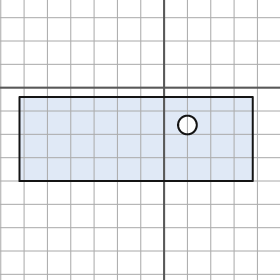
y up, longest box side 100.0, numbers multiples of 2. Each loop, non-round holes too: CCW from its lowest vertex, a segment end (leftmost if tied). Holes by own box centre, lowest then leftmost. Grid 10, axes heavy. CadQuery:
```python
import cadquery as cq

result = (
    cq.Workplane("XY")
    .moveTo(-62.0, -40.0)
    .lineTo(38.0, -40.0)
    .lineTo(38.0, -4.0)
    .lineTo(-62.0, -4.0)
    .close()
    .moveTo(10.0, -16.0)
    .circle(4.0)
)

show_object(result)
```